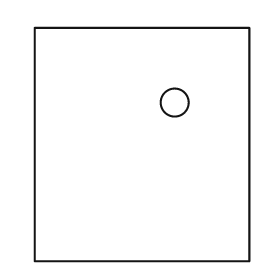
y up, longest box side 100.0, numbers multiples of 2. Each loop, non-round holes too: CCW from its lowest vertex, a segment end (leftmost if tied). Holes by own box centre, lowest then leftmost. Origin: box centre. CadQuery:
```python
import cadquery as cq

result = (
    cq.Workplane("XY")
    .moveTo(-46.0, -50.0)
    .lineTo(46.0, -50.0)
    .lineTo(46.0, 50.0)
    .lineTo(-46.0, 50.0)
    .close()
    .moveTo(14.0, 18.0)
    .circle(6.0)
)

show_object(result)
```